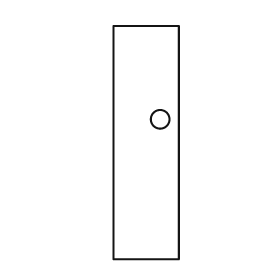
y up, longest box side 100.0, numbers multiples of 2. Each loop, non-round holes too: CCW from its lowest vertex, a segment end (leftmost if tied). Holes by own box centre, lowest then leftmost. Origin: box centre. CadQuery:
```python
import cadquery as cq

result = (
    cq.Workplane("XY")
    .moveTo(-14.0, -50.0)
    .lineTo(14.0, -50.0)
    .lineTo(14.0, 50.0)
    .lineTo(-14.0, 50.0)
    .close()
    .moveTo(6.0, 10.0)
    .circle(4.0)
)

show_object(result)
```